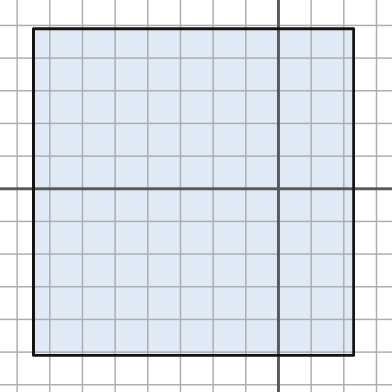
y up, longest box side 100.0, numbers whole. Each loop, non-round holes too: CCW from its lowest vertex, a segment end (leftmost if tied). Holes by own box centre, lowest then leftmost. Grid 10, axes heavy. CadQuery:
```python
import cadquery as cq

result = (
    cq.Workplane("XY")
    .moveTo(-75.0, -51.0)
    .lineTo(23.0, -51.0)
    .lineTo(23.0, 49.0)
    .lineTo(-75.0, 49.0)
    .close()
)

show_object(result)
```